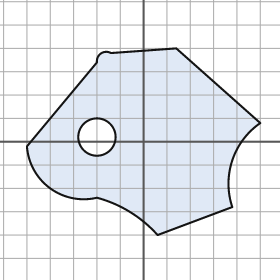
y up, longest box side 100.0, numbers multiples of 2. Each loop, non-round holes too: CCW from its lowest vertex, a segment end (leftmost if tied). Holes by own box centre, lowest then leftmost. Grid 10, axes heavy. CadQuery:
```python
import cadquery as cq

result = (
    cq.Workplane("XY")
    .moveTo(6.0, -40.0)
    .lineTo(38.0, -28.0)
    .threePointArc((38.0, -8.0), (50.0, 8.0))
    .lineTo(14.0, 40.0)
    .lineTo(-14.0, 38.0)
    .threePointArc((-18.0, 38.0), (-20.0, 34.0))
    .lineTo(-50.0, -2.0)
    .threePointArc((-40.0, -20.0), (-20.0, -24.0))
    .threePointArc((-6.0, -30.0), (6.0, -40.0))
    .close()
    .moveTo(-20.0, 2.0)
    .circle(8.0)
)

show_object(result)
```